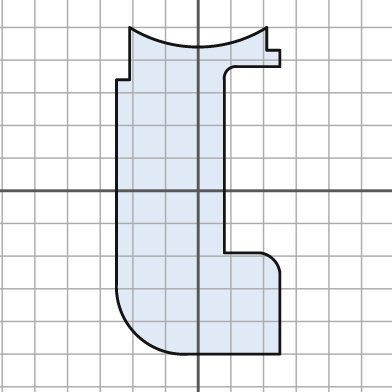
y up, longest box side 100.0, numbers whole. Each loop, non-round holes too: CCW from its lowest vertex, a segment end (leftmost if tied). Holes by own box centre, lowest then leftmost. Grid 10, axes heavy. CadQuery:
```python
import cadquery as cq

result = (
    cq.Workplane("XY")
    .moveTo(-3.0, -50.0)
    .lineTo(25.0, -50.0)
    .lineTo(25.0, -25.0)
    .threePointArc((23.0, -21.0), (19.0, -19.0))
    .lineTo(8.0, -19.0)
    .lineTo(8.0, 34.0)
    .threePointArc((9.0, 37.0), (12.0, 38.0))
    .lineTo(25.0, 38.0)
    .lineTo(25.0, 43.0)
    .lineTo(21.0, 43.0)
    .lineTo(21.0, 50.0)
    .threePointArc((0.0, 44.0), (-21.0, 50.0))
    .lineTo(-21.0, 34.0)
    .lineTo(-25.0, 34.0)
    .lineTo(-25.0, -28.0)
    .threePointArc((-19.0, -44.0), (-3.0, -50.0))
    .close()
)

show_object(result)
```